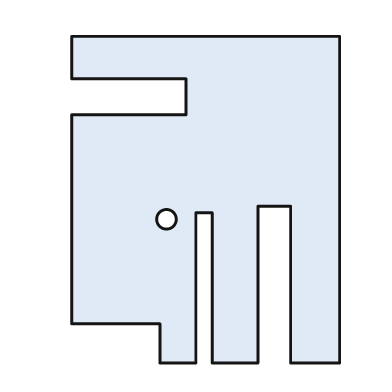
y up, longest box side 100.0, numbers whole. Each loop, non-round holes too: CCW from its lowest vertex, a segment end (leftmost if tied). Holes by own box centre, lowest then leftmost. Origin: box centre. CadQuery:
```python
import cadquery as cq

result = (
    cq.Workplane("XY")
    .moveTo(-14.0, -50.0)
    .lineTo(-3.0, -50.0)
    .lineTo(-3.0, -4.0)
    .lineTo(2.0, -4.0)
    .lineTo(2.0, -50.0)
    .lineTo(16.0, -50.0)
    .lineTo(16.0, -2.0)
    .lineTo(26.0, -2.0)
    .lineTo(26.0, -50.0)
    .lineTo(41.0, -50.0)
    .lineTo(41.0, 50.0)
    .lineTo(-41.0, 50.0)
    .lineTo(-41.0, 37.0)
    .lineTo(-6.0, 37.0)
    .lineTo(-6.0, 26.0)
    .lineTo(-41.0, 26.0)
    .lineTo(-41.0, -38.0)
    .lineTo(-14.0, -38.0)
    .close()
    .moveTo(-12.0, -6.0)
    .circle(3.0)
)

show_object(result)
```